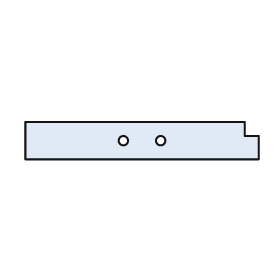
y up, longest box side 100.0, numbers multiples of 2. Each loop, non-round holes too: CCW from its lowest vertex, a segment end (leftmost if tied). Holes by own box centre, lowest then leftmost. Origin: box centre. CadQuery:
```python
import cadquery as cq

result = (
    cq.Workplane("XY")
    .moveTo(-50.0, -8.0)
    .lineTo(50.0, -8.0)
    .lineTo(50.0, 2.0)
    .lineTo(44.0, 2.0)
    .lineTo(44.0, 8.0)
    .lineTo(-50.0, 8.0)
    .close()
    .moveTo(-8.0, 0.0)
    .circle(2.0)
    .moveTo(8.0, 0.0)
    .circle(2.0)
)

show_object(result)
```